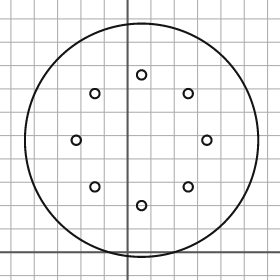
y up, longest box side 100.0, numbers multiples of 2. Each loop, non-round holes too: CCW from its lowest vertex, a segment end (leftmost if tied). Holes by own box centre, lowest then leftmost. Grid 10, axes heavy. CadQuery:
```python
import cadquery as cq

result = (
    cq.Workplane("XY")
    .moveTo(6.0, 48.0)
    .circle(50.0)
    .moveTo(6.0, 20.0)
    .circle(2.0)
    .moveTo(-14.0, 28.0)
    .circle(2.0)
    .moveTo(26.0, 28.0)
    .circle(2.0)
    .moveTo(-22.0, 48.0)
    .circle(2.0)
    .moveTo(34.0, 48.0)
    .circle(2.0)
    .moveTo(-14.0, 68.0)
    .circle(2.0)
    .moveTo(26.0, 68.0)
    .circle(2.0)
    .moveTo(6.0, 76.0)
    .circle(2.0)
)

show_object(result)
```